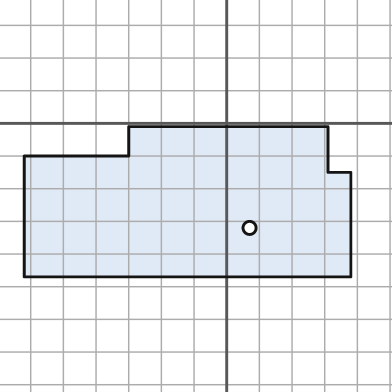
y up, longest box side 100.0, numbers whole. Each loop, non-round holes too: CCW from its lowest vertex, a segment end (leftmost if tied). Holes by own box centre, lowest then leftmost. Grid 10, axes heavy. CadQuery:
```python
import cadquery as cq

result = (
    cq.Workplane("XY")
    .moveTo(-62.0, -47.0)
    .lineTo(38.0, -47.0)
    .lineTo(38.0, -15.0)
    .lineTo(31.0, -15.0)
    .lineTo(31.0, -1.0)
    .lineTo(-30.0, -1.0)
    .lineTo(-30.0, -10.0)
    .lineTo(-62.0, -10.0)
    .close()
    .moveTo(7.0, -32.0)
    .circle(2.0)
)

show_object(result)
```